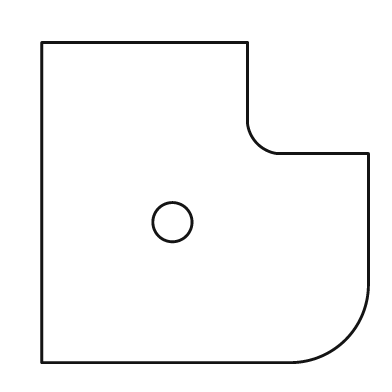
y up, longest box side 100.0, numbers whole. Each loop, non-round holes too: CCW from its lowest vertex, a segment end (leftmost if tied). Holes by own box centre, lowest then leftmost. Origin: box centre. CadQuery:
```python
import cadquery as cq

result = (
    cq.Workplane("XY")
    .moveTo(-50.0, -49.0)
    .lineTo(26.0, -49.0)
    .threePointArc((43.0, -42.0), (50.0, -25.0))
    .lineTo(50.0, 15.0)
    .lineTo(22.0, 15.0)
    .threePointArc((16.0, 18.0), (13.0, 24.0))
    .lineTo(13.0, 49.0)
    .lineTo(-50.0, 49.0)
    .close()
    .moveTo(-10.0, -6.0)
    .circle(6.0)
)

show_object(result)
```